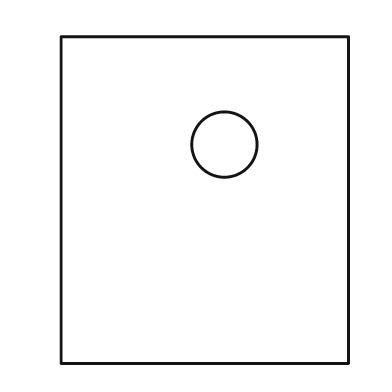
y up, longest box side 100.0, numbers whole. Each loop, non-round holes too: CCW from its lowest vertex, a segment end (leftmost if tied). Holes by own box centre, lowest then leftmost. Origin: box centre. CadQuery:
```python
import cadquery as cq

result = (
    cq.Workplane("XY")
    .moveTo(-44.0, -50.0)
    .lineTo(44.0, -50.0)
    .lineTo(44.0, 50.0)
    .lineTo(-44.0, 50.0)
    .close()
    .moveTo(6.0, 17.0)
    .circle(10.0)
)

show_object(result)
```